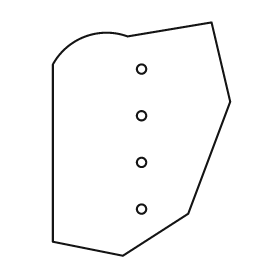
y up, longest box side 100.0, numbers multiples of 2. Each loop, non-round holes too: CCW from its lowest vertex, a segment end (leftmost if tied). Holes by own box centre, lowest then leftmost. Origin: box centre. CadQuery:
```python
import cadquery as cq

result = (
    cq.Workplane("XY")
    .moveTo(-8.0, -50.0)
    .lineTo(20.0, -32.0)
    .lineTo(38.0, 16.0)
    .lineTo(30.0, 50.0)
    .lineTo(-6.0, 44.0)
    .threePointArc((-24.0, 44.0), (-38.0, 32.0))
    .lineTo(-38.0, -44.0)
    .close()
    .moveTo(0.0, -30.0)
    .circle(2.0)
    .moveTo(0.0, -10.0)
    .circle(2.0)
    .moveTo(0.0, 10.0)
    .circle(2.0)
    .moveTo(0.0, 30.0)
    .circle(2.0)
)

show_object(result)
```